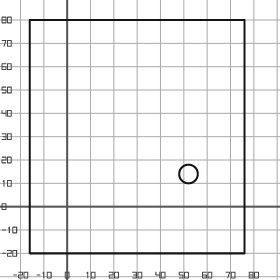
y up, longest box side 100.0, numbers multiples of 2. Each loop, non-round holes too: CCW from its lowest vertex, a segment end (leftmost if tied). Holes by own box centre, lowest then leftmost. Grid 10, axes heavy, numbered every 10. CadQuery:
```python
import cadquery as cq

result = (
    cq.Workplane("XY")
    .moveTo(-16.0, -20.0)
    .lineTo(76.0, -20.0)
    .lineTo(76.0, 80.0)
    .lineTo(-16.0, 80.0)
    .close()
    .moveTo(52.0, 14.0)
    .circle(4.0)
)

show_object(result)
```